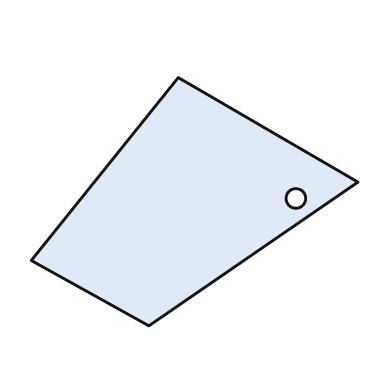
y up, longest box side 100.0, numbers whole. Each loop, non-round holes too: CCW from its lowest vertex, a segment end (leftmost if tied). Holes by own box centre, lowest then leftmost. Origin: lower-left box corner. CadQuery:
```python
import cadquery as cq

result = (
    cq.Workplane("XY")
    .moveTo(36.0, 0.0)
    .lineTo(100.0, 44.0)
    .lineTo(45.0, 76.0)
    .lineTo(0.0, 20.0)
    .close()
    .moveTo(81.0, 39.0)
    .circle(3.0)
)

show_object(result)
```